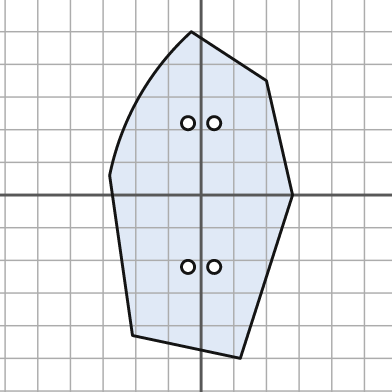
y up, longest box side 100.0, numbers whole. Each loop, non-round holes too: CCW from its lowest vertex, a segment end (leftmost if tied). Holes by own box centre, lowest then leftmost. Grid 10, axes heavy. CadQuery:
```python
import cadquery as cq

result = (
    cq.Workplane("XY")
    .moveTo(12.0, -50.0)
    .lineTo(28.0, 0.0)
    .lineTo(20.0, 35.0)
    .lineTo(-3.0, 50.0)
    .threePointArc((-19.0, 30.0), (-28.0, 6.0))
    .lineTo(-21.0, -43.0)
    .close()
    .moveTo(-4.0, -22.0)
    .circle(2.0)
    .moveTo(4.0, -22.0)
    .circle(2.0)
    .moveTo(-4.0, 22.0)
    .circle(2.0)
    .moveTo(4.0, 22.0)
    .circle(2.0)
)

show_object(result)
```